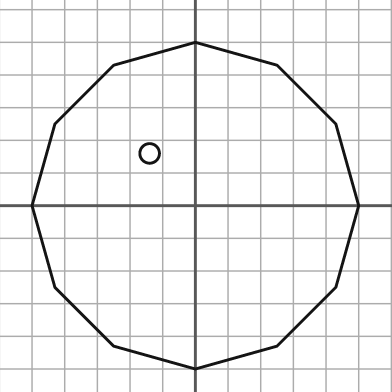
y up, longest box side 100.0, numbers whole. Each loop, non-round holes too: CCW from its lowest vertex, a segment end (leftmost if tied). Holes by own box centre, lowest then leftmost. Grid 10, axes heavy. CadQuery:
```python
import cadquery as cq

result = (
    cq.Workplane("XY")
    .moveTo(0.0, -50.0)
    .lineTo(25.0, -43.0)
    .lineTo(43.0, -25.0)
    .lineTo(50.0, 0.0)
    .lineTo(43.0, 25.0)
    .lineTo(25.0, 43.0)
    .lineTo(0.0, 50.0)
    .lineTo(-25.0, 43.0)
    .lineTo(-43.0, 25.0)
    .lineTo(-50.0, 0.0)
    .lineTo(-43.0, -25.0)
    .lineTo(-25.0, -43.0)
    .close()
    .moveTo(-14.0, 16.0)
    .circle(3.0)
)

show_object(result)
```